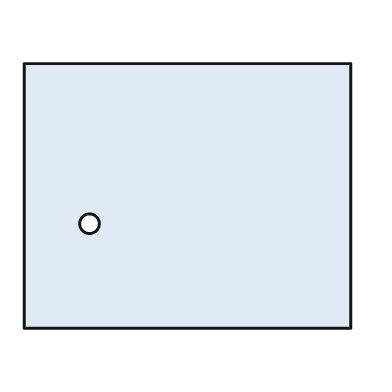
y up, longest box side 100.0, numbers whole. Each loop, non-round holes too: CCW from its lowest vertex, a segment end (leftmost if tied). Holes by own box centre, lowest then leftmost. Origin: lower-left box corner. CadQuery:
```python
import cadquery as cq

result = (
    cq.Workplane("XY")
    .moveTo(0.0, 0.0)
    .lineTo(100.0, 0.0)
    .lineTo(100.0, 81.0)
    .lineTo(0.0, 81.0)
    .close()
    .moveTo(20.0, 32.0)
    .circle(3.0)
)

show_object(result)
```